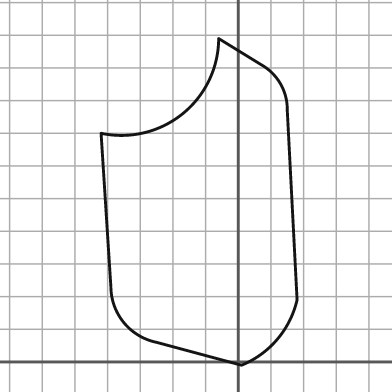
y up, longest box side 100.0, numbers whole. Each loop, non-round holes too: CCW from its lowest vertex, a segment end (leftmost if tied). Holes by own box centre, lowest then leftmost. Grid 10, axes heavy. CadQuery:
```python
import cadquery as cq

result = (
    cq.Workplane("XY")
    .moveTo(1.0, -1.0)
    .threePointArc((12.0, 7.0), (18.0, 19.0))
    .lineTo(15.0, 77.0)
    .threePointArc((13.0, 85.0), (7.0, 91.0))
    .lineTo(-6.0, 99.0)
    .threePointArc((-17.0, 76.0), (-42.0, 70.0))
    .lineTo(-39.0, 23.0)
    .threePointArc((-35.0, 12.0), (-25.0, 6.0))
    .close()
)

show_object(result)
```